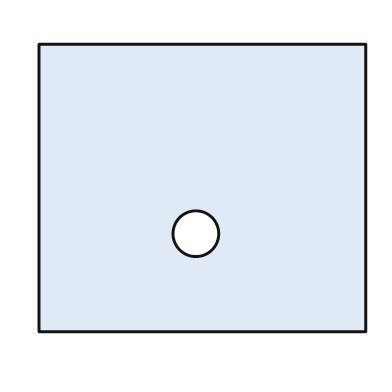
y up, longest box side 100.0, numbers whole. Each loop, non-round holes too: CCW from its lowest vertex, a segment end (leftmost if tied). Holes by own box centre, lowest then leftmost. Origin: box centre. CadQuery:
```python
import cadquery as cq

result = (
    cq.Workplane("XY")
    .moveTo(-50.0, -44.0)
    .lineTo(50.0, -44.0)
    .lineTo(50.0, 44.0)
    .lineTo(-50.0, 44.0)
    .close()
    .moveTo(-2.0, -14.0)
    .circle(7.0)
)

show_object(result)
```